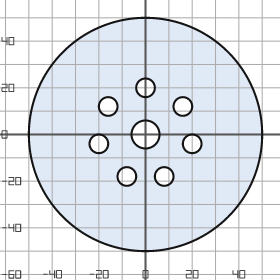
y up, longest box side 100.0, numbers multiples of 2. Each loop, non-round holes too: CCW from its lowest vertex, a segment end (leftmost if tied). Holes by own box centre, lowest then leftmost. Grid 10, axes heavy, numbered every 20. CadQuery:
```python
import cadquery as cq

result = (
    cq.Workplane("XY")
    .moveTo(0.0, 0.0)
    .circle(50.0)
    .moveTo(-8.0, -18.0)
    .circle(4.0)
    .moveTo(8.0, -18.0)
    .circle(4.0)
    .moveTo(-20.0, -4.0)
    .circle(4.0)
    .moveTo(20.0, -4.0)
    .circle(4.0)
    .moveTo(0.0, 0.0)
    .circle(6.0)
    .moveTo(-16.0, 12.0)
    .circle(4.0)
    .moveTo(16.0, 12.0)
    .circle(4.0)
    .moveTo(0.0, 20.0)
    .circle(4.0)
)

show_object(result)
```